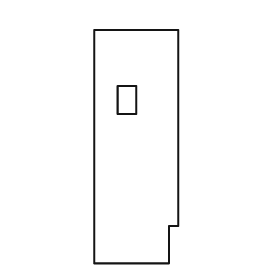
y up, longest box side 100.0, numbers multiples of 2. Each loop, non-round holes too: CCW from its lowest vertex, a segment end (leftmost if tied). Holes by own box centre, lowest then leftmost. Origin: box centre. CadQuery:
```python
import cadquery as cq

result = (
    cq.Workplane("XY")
    .moveTo(-18.0, -50.0)
    .lineTo(14.0, -50.0)
    .lineTo(14.0, -34.0)
    .lineTo(18.0, -34.0)
    .lineTo(18.0, 50.0)
    .lineTo(-18.0, 50.0)
    .close()
    .moveTo(-8.0, 14.0)
    .lineTo(0.0, 14.0)
    .lineTo(0.0, 26.0)
    .lineTo(-8.0, 26.0)
    .close()
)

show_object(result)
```